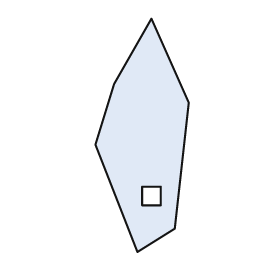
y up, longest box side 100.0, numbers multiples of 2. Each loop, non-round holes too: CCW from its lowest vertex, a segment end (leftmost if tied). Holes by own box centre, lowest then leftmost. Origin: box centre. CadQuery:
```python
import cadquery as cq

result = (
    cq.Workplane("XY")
    .moveTo(-2.0, -50.0)
    .lineTo(14.0, -40.0)
    .lineTo(20.0, 14.0)
    .lineTo(4.0, 50.0)
    .lineTo(-12.0, 22.0)
    .lineTo(-20.0, -4.0)
    .close()
    .moveTo(0.0, -30.0)
    .lineTo(8.0, -30.0)
    .lineTo(8.0, -22.0)
    .lineTo(0.0, -22.0)
    .close()
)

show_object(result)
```